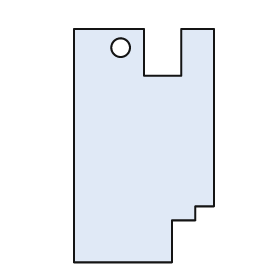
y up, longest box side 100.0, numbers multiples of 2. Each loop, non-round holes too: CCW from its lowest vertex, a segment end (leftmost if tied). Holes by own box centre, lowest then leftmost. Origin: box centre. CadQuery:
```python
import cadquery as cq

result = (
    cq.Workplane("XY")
    .moveTo(-30.0, -50.0)
    .lineTo(12.0, -50.0)
    .lineTo(12.0, -32.0)
    .lineTo(22.0, -32.0)
    .lineTo(22.0, -26.0)
    .lineTo(30.0, -26.0)
    .lineTo(30.0, 50.0)
    .lineTo(16.0, 50.0)
    .lineTo(16.0, 30.0)
    .lineTo(0.0, 30.0)
    .lineTo(0.0, 50.0)
    .lineTo(-30.0, 50.0)
    .close()
    .moveTo(-10.0, 42.0)
    .circle(4.0)
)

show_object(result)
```